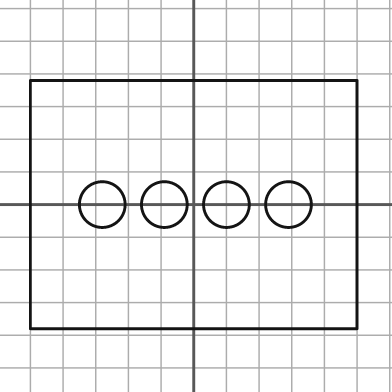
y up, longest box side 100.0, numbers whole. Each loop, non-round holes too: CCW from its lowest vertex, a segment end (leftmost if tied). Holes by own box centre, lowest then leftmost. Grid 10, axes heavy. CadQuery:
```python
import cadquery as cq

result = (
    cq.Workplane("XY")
    .moveTo(-50.0, -38.0)
    .lineTo(50.0, -38.0)
    .lineTo(50.0, 38.0)
    .lineTo(-50.0, 38.0)
    .close()
    .moveTo(-28.0, 0.0)
    .circle(7.0)
    .moveTo(-9.0, 0.0)
    .circle(7.0)
    .moveTo(10.0, 0.0)
    .circle(7.0)
    .moveTo(29.0, 0.0)
    .circle(7.0)
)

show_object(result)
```